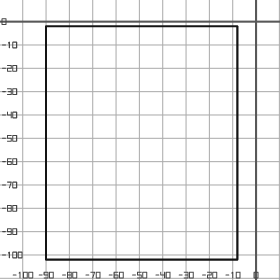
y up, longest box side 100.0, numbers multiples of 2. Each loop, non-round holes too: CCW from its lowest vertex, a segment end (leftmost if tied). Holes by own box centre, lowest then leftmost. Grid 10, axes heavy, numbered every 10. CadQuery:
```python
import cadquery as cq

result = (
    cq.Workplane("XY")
    .moveTo(-90.0, -102.0)
    .lineTo(-8.0, -102.0)
    .lineTo(-8.0, -2.0)
    .lineTo(-90.0, -2.0)
    .close()
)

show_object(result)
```